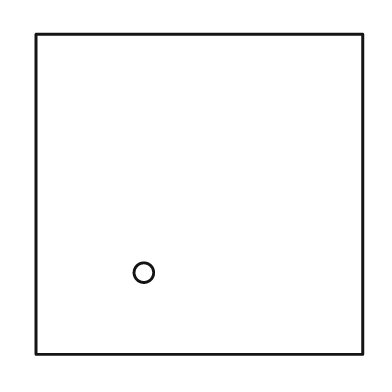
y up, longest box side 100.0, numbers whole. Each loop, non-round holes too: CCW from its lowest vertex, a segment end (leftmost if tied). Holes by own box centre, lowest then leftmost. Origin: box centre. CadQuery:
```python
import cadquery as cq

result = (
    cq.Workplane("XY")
    .moveTo(-50.0, -49.0)
    .lineTo(50.0, -49.0)
    .lineTo(50.0, 49.0)
    .lineTo(-50.0, 49.0)
    .close()
    .moveTo(-17.0, -24.0)
    .circle(3.0)
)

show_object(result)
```